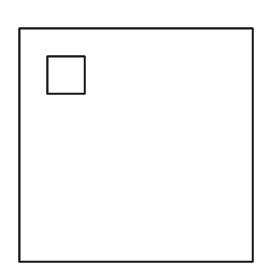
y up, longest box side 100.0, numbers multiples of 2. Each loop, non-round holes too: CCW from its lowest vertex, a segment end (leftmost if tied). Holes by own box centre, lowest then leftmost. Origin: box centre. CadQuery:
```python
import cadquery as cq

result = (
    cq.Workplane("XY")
    .moveTo(-50.0, -50.0)
    .lineTo(50.0, -50.0)
    .lineTo(50.0, 50.0)
    .lineTo(-50.0, 50.0)
    .close()
    .moveTo(-38.0, 22.0)
    .lineTo(-22.0, 22.0)
    .lineTo(-22.0, 38.0)
    .lineTo(-38.0, 38.0)
    .close()
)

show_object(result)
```